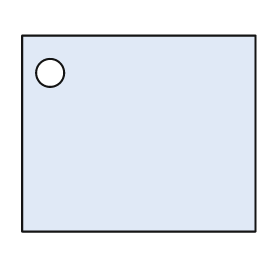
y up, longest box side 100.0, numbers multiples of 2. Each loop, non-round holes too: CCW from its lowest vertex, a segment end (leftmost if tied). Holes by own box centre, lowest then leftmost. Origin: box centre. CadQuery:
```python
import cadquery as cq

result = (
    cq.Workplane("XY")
    .moveTo(-50.0, -42.0)
    .lineTo(50.0, -42.0)
    .lineTo(50.0, 42.0)
    .lineTo(-50.0, 42.0)
    .close()
    .moveTo(-38.0, 26.0)
    .circle(6.0)
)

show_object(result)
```